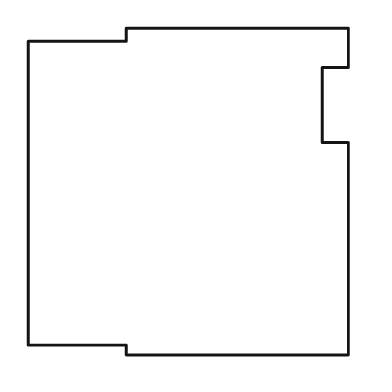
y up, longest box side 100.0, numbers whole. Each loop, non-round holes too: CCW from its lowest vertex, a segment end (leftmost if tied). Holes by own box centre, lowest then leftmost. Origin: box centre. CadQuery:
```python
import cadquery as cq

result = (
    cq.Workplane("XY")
    .moveTo(-19.0, -50.0)
    .lineTo(49.0, -50.0)
    .lineTo(49.0, 15.0)
    .lineTo(41.0, 15.0)
    .lineTo(41.0, 38.0)
    .lineTo(49.0, 38.0)
    .lineTo(49.0, 50.0)
    .lineTo(-19.0, 50.0)
    .lineTo(-19.0, 46.0)
    .lineTo(-49.0, 46.0)
    .lineTo(-49.0, -47.0)
    .lineTo(-19.0, -47.0)
    .close()
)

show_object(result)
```